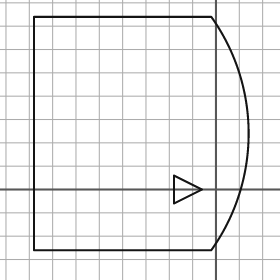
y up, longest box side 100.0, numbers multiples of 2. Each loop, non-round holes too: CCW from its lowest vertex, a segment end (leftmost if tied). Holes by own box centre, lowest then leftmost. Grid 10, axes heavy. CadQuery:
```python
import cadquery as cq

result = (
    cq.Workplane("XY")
    .moveTo(-78.0, -26.0)
    .lineTo(-2.0, -26.0)
    .threePointArc((14.0, 24.0), (-2.0, 74.0))
    .lineTo(-78.0, 74.0)
    .close()
    .moveTo(-18.0, -6.0)
    .lineTo(-6.0, 0.0)
    .lineTo(-18.0, 6.0)
    .close()
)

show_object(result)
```